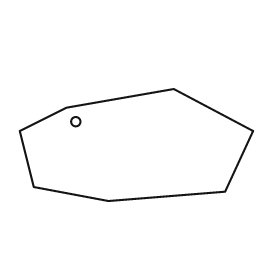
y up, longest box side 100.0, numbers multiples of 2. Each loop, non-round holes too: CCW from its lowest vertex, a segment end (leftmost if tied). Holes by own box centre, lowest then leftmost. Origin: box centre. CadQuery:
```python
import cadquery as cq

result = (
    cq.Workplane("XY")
    .moveTo(-12.0, -24.0)
    .lineTo(38.0, -20.0)
    .lineTo(50.0, 6.0)
    .lineTo(16.0, 24.0)
    .lineTo(-30.0, 16.0)
    .lineTo(-50.0, 6.0)
    .lineTo(-44.0, -18.0)
    .close()
    .moveTo(-26.0, 10.0)
    .circle(2.0)
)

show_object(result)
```